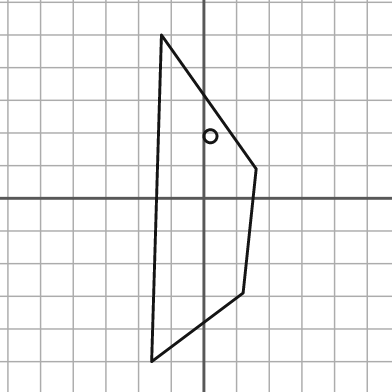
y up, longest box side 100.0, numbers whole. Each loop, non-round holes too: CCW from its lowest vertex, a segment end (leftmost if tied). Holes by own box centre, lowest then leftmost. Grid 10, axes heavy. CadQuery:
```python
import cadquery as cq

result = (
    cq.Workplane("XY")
    .moveTo(-16.0, -50.0)
    .lineTo(12.0, -29.0)
    .lineTo(16.0, 9.0)
    .lineTo(-13.0, 50.0)
    .close()
    .moveTo(2.0, 19.0)
    .circle(2.0)
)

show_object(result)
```